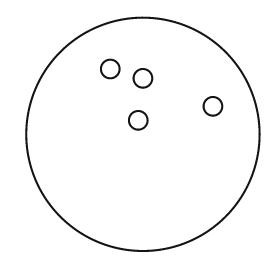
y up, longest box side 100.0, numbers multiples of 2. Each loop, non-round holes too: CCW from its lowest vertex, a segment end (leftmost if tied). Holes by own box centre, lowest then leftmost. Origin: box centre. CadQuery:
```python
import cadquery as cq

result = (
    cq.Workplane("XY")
    .moveTo(0.0, 0.0)
    .circle(50.0)
    .moveTo(-2.0, 6.0)
    .circle(4.0)
    .moveTo(30.0, 12.0)
    .circle(4.0)
    .moveTo(0.0, 24.0)
    .circle(4.0)
    .moveTo(-14.0, 28.0)
    .circle(4.0)
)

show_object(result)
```